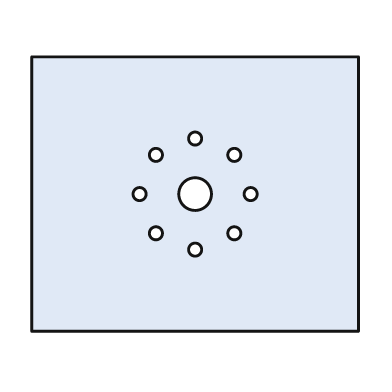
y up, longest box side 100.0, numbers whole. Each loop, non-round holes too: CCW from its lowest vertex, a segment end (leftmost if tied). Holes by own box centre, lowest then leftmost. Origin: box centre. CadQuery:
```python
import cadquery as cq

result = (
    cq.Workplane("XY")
    .moveTo(-50.0, -42.0)
    .lineTo(50.0, -42.0)
    .lineTo(50.0, 42.0)
    .lineTo(-50.0, 42.0)
    .close()
    .moveTo(0.0, -17.0)
    .circle(2.0)
    .moveTo(-12.0, -12.0)
    .circle(2.0)
    .moveTo(12.0, -12.0)
    .circle(2.0)
    .moveTo(-17.0, 0.0)
    .circle(2.0)
    .moveTo(0.0, 0.0)
    .circle(5.0)
    .moveTo(17.0, 0.0)
    .circle(2.0)
    .moveTo(-12.0, 12.0)
    .circle(2.0)
    .moveTo(12.0, 12.0)
    .circle(2.0)
    .moveTo(0.0, 17.0)
    .circle(2.0)
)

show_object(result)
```